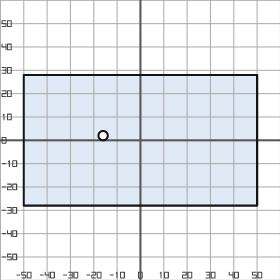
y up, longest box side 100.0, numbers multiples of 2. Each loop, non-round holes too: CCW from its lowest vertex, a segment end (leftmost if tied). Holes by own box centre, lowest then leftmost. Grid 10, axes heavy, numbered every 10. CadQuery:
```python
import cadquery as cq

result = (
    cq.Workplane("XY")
    .moveTo(-50.0, -28.0)
    .lineTo(50.0, -28.0)
    .lineTo(50.0, 28.0)
    .lineTo(-50.0, 28.0)
    .close()
    .moveTo(-16.0, 2.0)
    .circle(2.0)
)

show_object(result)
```